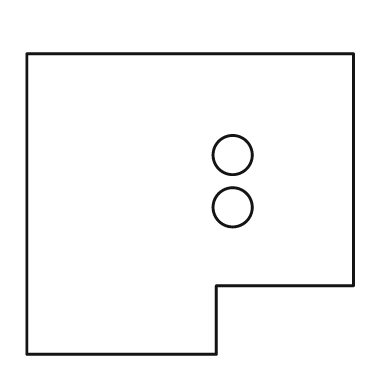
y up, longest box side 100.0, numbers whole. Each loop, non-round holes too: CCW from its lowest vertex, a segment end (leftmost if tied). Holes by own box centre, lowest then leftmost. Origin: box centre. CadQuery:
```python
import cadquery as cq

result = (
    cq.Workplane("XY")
    .moveTo(-50.0, -46.0)
    .lineTo(8.0, -46.0)
    .lineTo(8.0, -25.0)
    .lineTo(50.0, -25.0)
    .lineTo(50.0, 46.0)
    .lineTo(-50.0, 46.0)
    .close()
    .moveTo(13.0, -1.0)
    .circle(6.0)
    .moveTo(13.0, 15.0)
    .circle(6.0)
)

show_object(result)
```